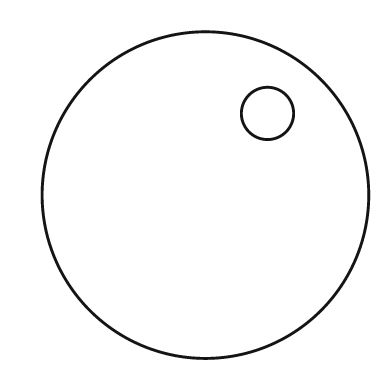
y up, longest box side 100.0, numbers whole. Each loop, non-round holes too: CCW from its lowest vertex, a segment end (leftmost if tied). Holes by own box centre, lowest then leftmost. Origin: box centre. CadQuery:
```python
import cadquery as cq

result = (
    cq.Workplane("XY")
    .moveTo(0.0, 0.0)
    .circle(50.0)
    .moveTo(19.0, 25.0)
    .circle(8.0)
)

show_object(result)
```